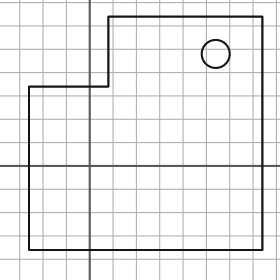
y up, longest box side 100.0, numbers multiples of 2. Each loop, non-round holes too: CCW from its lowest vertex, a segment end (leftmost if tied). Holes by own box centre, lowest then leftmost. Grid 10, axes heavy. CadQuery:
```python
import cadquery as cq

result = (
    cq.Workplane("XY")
    .moveTo(-26.0, -36.0)
    .lineTo(74.0, -36.0)
    .lineTo(74.0, 64.0)
    .lineTo(8.0, 64.0)
    .lineTo(8.0, 34.0)
    .lineTo(-26.0, 34.0)
    .close()
    .moveTo(54.0, 48.0)
    .circle(6.0)
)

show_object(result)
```